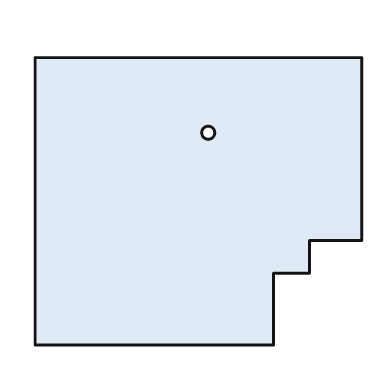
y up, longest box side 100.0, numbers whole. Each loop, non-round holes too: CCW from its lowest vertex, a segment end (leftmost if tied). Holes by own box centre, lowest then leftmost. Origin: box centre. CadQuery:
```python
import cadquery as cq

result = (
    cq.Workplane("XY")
    .moveTo(-50.0, -44.0)
    .lineTo(23.0, -44.0)
    .lineTo(23.0, -22.0)
    .lineTo(34.0, -22.0)
    .lineTo(34.0, -12.0)
    .lineTo(50.0, -12.0)
    .lineTo(50.0, 44.0)
    .lineTo(-50.0, 44.0)
    .close()
    .moveTo(3.0, 21.0)
    .circle(2.0)
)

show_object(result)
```